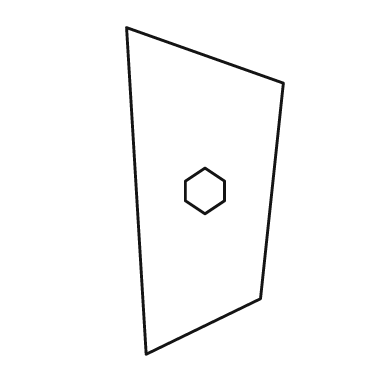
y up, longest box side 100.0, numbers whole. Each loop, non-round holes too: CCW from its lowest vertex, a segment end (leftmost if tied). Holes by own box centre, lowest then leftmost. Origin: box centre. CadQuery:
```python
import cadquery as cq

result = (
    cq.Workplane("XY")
    .moveTo(-18.0, -50.0)
    .lineTo(17.0, -33.0)
    .lineTo(24.0, 33.0)
    .lineTo(-24.0, 50.0)
    .close()
    .moveTo(0.0, -7.0)
    .lineTo(6.0, -3.0)
    .lineTo(6.0, 3.0)
    .lineTo(0.0, 7.0)
    .lineTo(-6.0, 3.0)
    .lineTo(-6.0, -3.0)
    .close()
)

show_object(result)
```